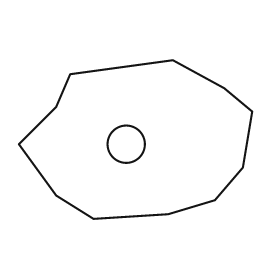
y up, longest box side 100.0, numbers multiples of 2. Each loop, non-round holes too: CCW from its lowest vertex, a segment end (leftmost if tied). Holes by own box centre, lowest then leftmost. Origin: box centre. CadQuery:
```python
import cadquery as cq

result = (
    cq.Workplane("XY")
    .moveTo(-18.0, -34.0)
    .lineTo(14.0, -32.0)
    .lineTo(34.0, -26.0)
    .lineTo(46.0, -12.0)
    .lineTo(50.0, 12.0)
    .lineTo(38.0, 22.0)
    .lineTo(16.0, 34.0)
    .lineTo(-28.0, 28.0)
    .lineTo(-34.0, 14.0)
    .lineTo(-50.0, -2.0)
    .lineTo(-34.0, -24.0)
    .close()
    .moveTo(-4.0, -2.0)
    .circle(8.0)
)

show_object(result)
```